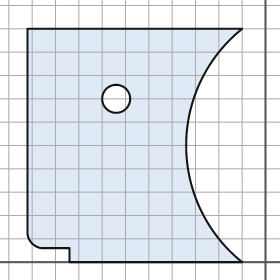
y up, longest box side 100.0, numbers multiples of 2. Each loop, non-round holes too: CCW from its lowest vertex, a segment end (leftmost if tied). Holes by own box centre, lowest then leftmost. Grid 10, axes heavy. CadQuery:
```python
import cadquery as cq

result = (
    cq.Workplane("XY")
    .moveTo(-84.0, 0.0)
    .lineTo(-10.0, 0.0)
    .threePointArc((-34.0, 50.0), (-10.0, 100.0))
    .lineTo(-102.0, 100.0)
    .lineTo(-102.0, 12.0)
    .threePointArc((-100.0, 8.0), (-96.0, 6.0))
    .lineTo(-84.0, 6.0)
    .close()
    .moveTo(-64.0, 70.0)
    .circle(6.0)
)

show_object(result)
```